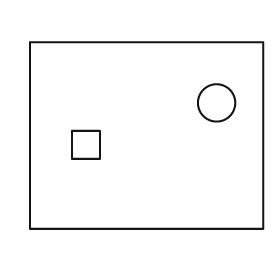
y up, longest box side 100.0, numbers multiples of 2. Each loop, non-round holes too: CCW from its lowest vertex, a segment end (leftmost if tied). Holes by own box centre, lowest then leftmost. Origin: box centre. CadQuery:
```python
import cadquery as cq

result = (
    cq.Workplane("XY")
    .moveTo(-50.0, -40.0)
    .lineTo(50.0, -40.0)
    .lineTo(50.0, 40.0)
    .lineTo(-50.0, 40.0)
    .close()
    .moveTo(-32.0, -10.0)
    .lineTo(-20.0, -10.0)
    .lineTo(-20.0, 2.0)
    .lineTo(-32.0, 2.0)
    .close()
    .moveTo(30.0, 14.0)
    .circle(8.0)
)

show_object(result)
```